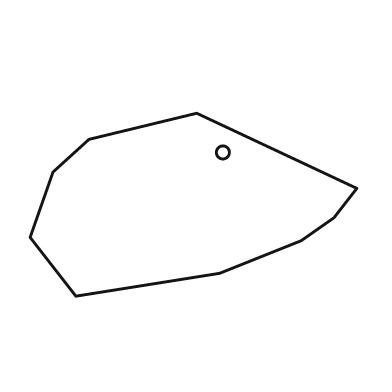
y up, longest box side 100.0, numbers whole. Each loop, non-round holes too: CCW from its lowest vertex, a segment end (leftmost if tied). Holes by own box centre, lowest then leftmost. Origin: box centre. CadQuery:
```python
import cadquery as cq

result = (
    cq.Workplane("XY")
    .moveTo(-36.0, -28.0)
    .lineTo(8.0, -21.0)
    .lineTo(33.0, -11.0)
    .lineTo(43.0, -4.0)
    .lineTo(50.0, 5.0)
    .lineTo(1.0, 28.0)
    .lineTo(-32.0, 20.0)
    .lineTo(-43.0, 10.0)
    .lineTo(-50.0, -10.0)
    .close()
    .moveTo(9.0, 16.0)
    .circle(2.0)
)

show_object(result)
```